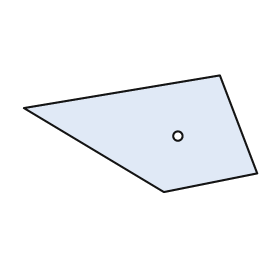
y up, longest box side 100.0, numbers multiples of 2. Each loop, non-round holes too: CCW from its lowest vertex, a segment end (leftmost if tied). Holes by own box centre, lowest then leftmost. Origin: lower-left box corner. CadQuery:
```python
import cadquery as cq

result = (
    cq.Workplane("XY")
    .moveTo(60.0, 0.0)
    .lineTo(100.0, 8.0)
    .lineTo(84.0, 50.0)
    .lineTo(0.0, 36.0)
    .close()
    .moveTo(66.0, 24.0)
    .circle(2.0)
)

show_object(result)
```